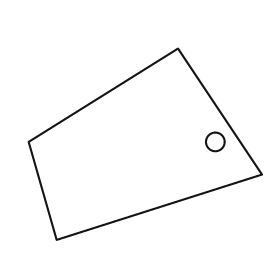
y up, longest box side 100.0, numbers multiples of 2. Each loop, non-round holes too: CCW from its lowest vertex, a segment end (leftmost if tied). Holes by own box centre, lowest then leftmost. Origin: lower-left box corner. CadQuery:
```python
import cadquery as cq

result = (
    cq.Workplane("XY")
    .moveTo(12.0, 0.0)
    .lineTo(100.0, 28.0)
    .lineTo(64.0, 82.0)
    .lineTo(0.0, 42.0)
    .close()
    .moveTo(80.0, 42.0)
    .circle(4.0)
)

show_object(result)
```